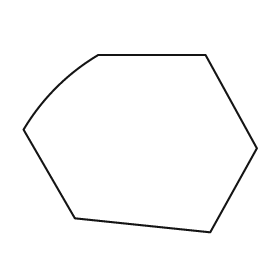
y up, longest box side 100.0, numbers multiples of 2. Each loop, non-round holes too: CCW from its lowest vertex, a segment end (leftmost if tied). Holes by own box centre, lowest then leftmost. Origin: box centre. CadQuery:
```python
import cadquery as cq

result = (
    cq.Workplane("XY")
    .moveTo(30.0, -38.0)
    .lineTo(50.0, -2.0)
    .lineTo(28.0, 38.0)
    .lineTo(-18.0, 38.0)
    .threePointArc((-36.0, 24.0), (-50.0, 6.0))
    .lineTo(-28.0, -32.0)
    .close()
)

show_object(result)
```